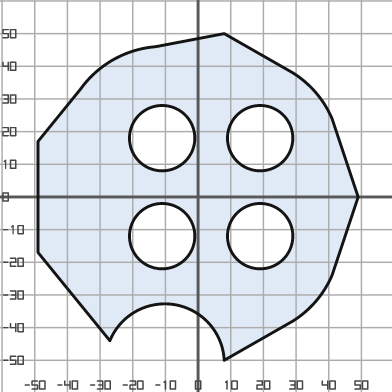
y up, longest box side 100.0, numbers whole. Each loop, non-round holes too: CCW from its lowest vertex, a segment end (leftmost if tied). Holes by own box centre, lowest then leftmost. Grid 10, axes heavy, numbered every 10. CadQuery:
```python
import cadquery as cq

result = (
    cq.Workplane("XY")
    .moveTo(8.0, -50.0)
    .lineTo(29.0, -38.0)
    .threePointArc((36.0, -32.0), (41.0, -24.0))
    .lineTo(49.0, 0.0)
    .lineTo(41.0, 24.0)
    .threePointArc((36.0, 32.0), (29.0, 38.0))
    .lineTo(8.0, 50.0)
    .lineTo(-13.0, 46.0)
    .threePointArc((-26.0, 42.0), (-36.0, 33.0))
    .lineTo(-49.0, 17.0)
    .lineTo(-49.0, -17.0)
    .lineTo(-27.0, -44.0)
    .threePointArc((-7.0, -33.0), (8.0, -50.0))
    .close()
    .moveTo(-11.0, -12.0)
    .circle(10.0)
    .moveTo(19.0, -12.0)
    .circle(10.0)
    .moveTo(-11.0, 18.0)
    .circle(10.0)
    .moveTo(19.0, 18.0)
    .circle(10.0)
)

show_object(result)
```